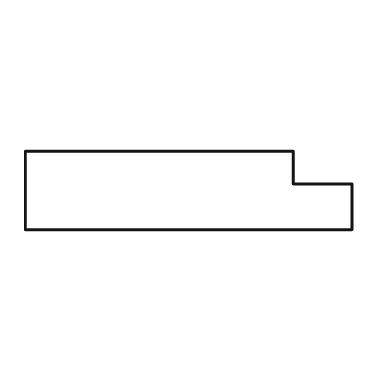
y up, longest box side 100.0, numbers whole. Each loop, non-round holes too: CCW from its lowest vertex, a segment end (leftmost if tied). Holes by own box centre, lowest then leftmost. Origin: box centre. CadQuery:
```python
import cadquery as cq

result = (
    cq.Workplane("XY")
    .moveTo(-50.0, -12.0)
    .lineTo(50.0, -12.0)
    .lineTo(50.0, 2.0)
    .lineTo(32.0, 2.0)
    .lineTo(32.0, 12.0)
    .lineTo(-50.0, 12.0)
    .close()
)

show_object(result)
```